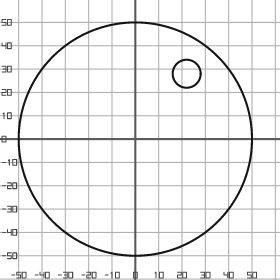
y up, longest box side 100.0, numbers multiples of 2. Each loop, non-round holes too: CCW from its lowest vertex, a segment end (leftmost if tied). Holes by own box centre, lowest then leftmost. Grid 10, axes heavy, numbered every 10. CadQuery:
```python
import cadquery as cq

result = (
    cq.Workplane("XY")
    .moveTo(0.0, 0.0)
    .circle(50.0)
    .moveTo(22.0, 28.0)
    .circle(6.0)
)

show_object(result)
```